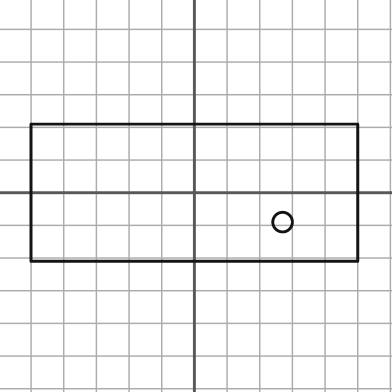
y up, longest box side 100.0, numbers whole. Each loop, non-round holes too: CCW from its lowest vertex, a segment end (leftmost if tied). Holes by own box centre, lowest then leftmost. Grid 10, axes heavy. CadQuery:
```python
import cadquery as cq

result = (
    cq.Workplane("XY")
    .moveTo(-50.0, -21.0)
    .lineTo(50.0, -21.0)
    .lineTo(50.0, 21.0)
    .lineTo(-50.0, 21.0)
    .close()
    .moveTo(27.0, -9.0)
    .circle(3.0)
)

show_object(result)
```